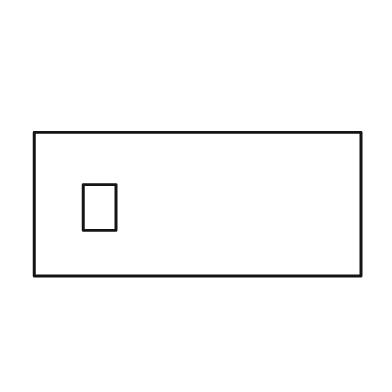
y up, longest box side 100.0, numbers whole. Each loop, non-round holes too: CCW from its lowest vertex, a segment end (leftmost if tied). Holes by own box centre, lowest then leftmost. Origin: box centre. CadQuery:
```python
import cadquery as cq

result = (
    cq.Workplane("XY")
    .moveTo(-50.0, -22.0)
    .lineTo(50.0, -22.0)
    .lineTo(50.0, 22.0)
    .lineTo(-50.0, 22.0)
    .close()
    .moveTo(-35.0, -8.0)
    .lineTo(-25.0, -8.0)
    .lineTo(-25.0, 6.0)
    .lineTo(-35.0, 6.0)
    .close()
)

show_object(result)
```